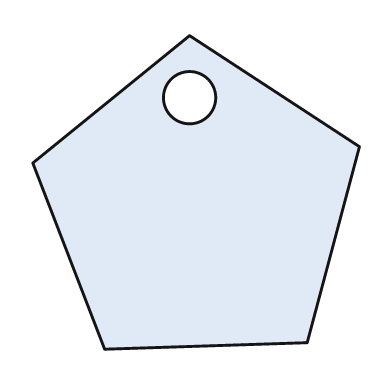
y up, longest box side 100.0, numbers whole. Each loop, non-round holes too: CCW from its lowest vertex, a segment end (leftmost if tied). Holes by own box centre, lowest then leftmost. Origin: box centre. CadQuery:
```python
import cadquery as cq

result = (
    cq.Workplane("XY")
    .moveTo(-28.0, -48.0)
    .lineTo(34.0, -46.0)
    .lineTo(50.0, 14.0)
    .lineTo(-2.0, 48.0)
    .lineTo(-50.0, 9.0)
    .close()
    .moveTo(-2.0, 29.0)
    .circle(8.0)
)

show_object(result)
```